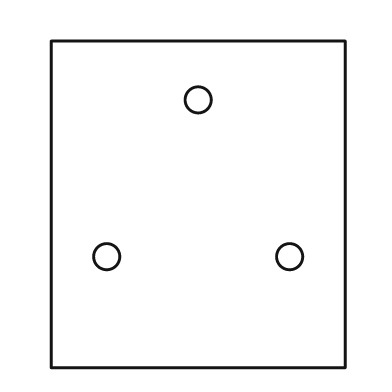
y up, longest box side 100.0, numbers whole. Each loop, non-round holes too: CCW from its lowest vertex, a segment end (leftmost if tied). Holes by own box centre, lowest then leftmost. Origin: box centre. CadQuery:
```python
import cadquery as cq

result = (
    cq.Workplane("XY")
    .moveTo(-45.0, -50.0)
    .lineTo(45.0, -50.0)
    .lineTo(45.0, 50.0)
    .lineTo(-45.0, 50.0)
    .close()
    .moveTo(-28.0, -16.0)
    .circle(4.0)
    .moveTo(28.0, -16.0)
    .circle(4.0)
    .moveTo(0.0, 32.0)
    .circle(4.0)
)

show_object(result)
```